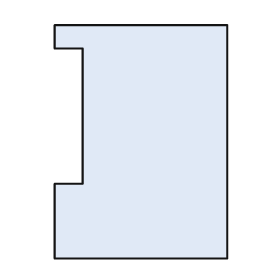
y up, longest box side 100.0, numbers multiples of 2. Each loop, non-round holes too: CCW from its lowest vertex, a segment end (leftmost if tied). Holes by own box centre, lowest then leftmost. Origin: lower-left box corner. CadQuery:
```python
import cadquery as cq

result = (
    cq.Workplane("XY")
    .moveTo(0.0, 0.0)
    .lineTo(74.0, 0.0)
    .lineTo(74.0, 100.0)
    .lineTo(0.0, 100.0)
    .lineTo(0.0, 90.0)
    .lineTo(12.0, 90.0)
    .lineTo(12.0, 32.0)
    .lineTo(0.0, 32.0)
    .close()
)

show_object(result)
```